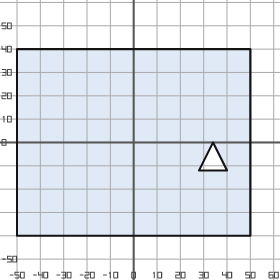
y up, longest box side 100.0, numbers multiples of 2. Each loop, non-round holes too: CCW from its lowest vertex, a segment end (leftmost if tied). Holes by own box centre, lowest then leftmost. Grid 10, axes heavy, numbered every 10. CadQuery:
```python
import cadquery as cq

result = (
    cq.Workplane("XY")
    .moveTo(-50.0, -40.0)
    .lineTo(50.0, -40.0)
    .lineTo(50.0, 40.0)
    .lineTo(-50.0, 40.0)
    .close()
    .moveTo(28.0, -12.0)
    .lineTo(40.0, -12.0)
    .lineTo(34.0, 0.0)
    .close()
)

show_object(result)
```